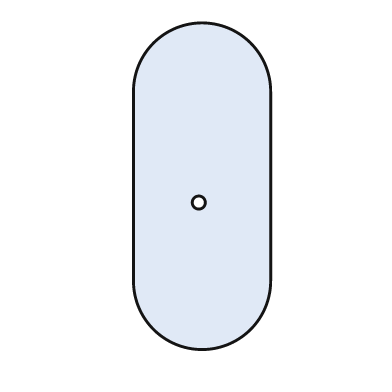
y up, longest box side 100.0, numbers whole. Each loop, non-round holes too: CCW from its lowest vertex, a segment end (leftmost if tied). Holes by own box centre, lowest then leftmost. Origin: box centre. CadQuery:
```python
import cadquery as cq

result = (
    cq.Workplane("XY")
    .moveTo(-21.0, -29.0)
    .threePointArc((0.0, -50.0), (21.0, -29.0))
    .lineTo(21.0, 29.0)
    .threePointArc((0.0, 50.0), (-21.0, 29.0))
    .close()
    .moveTo(-1.0, -5.0)
    .circle(2.0)
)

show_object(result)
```